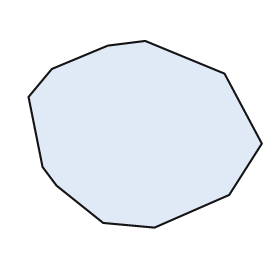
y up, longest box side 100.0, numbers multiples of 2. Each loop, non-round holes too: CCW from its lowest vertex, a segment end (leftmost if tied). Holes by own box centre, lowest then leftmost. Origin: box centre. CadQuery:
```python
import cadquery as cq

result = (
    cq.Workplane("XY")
    .moveTo(4.0, -40.0)
    .lineTo(36.0, -26.0)
    .lineTo(50.0, -4.0)
    .lineTo(34.0, 26.0)
    .lineTo(0.0, 40.0)
    .lineTo(-16.0, 38.0)
    .lineTo(-40.0, 28.0)
    .lineTo(-50.0, 16.0)
    .lineTo(-44.0, -14.0)
    .lineTo(-38.0, -22.0)
    .lineTo(-18.0, -38.0)
    .close()
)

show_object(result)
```